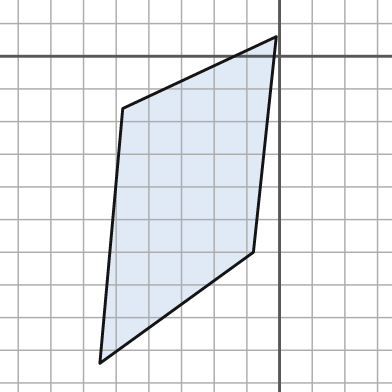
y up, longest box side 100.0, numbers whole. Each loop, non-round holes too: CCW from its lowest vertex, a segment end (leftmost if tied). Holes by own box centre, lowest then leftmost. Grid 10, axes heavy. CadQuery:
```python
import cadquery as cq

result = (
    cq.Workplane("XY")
    .moveTo(-55.0, -94.0)
    .lineTo(-8.0, -60.0)
    .lineTo(-1.0, 6.0)
    .lineTo(-48.0, -16.0)
    .close()
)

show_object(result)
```